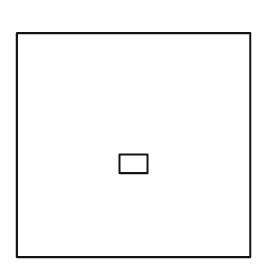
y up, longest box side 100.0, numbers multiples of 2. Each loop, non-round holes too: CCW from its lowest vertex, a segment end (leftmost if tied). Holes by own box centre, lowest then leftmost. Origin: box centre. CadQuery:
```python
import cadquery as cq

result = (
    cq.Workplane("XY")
    .moveTo(-50.0, -48.0)
    .lineTo(50.0, -48.0)
    .lineTo(50.0, 48.0)
    .lineTo(-50.0, 48.0)
    .close()
    .moveTo(-6.0, -12.0)
    .lineTo(6.0, -12.0)
    .lineTo(6.0, -4.0)
    .lineTo(-6.0, -4.0)
    .close()
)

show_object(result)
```